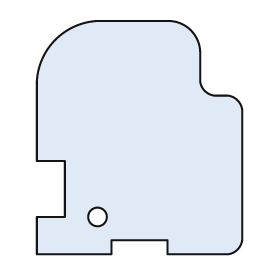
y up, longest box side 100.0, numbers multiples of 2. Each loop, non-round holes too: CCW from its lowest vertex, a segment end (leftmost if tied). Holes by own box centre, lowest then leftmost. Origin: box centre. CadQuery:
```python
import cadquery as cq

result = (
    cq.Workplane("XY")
    .moveTo(-44.0, -50.0)
    .lineTo(-12.0, -50.0)
    .lineTo(-12.0, -44.0)
    .lineTo(12.0, -44.0)
    .lineTo(12.0, -50.0)
    .lineTo(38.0, -50.0)
    .threePointArc((42.0, -48.0), (44.0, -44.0))
    .lineTo(44.0, 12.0)
    .threePointArc((42.0, 16.0), (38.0, 18.0))
    .lineTo(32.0, 18.0)
    .threePointArc((28.0, 20.0), (26.0, 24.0))
    .lineTo(26.0, 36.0)
    .threePointArc((22.0, 46.0), (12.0, 50.0))
    .lineTo(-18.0, 50.0)
    .threePointArc((-36.0, 42.0), (-44.0, 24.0))
    .lineTo(-44.0, -10.0)
    .lineTo(-32.0, -10.0)
    .lineTo(-32.0, -34.0)
    .lineTo(-44.0, -34.0)
    .close()
    .moveTo(-18.0, -34.0)
    .circle(4.0)
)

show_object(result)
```